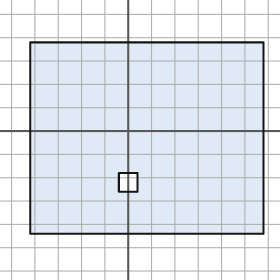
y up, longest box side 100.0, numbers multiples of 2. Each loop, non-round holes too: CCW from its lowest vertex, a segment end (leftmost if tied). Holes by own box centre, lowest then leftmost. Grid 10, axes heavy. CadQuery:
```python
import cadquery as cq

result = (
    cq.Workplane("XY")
    .moveTo(-42.0, -44.0)
    .lineTo(58.0, -44.0)
    .lineTo(58.0, 38.0)
    .lineTo(-42.0, 38.0)
    .close()
    .moveTo(-4.0, -26.0)
    .lineTo(4.0, -26.0)
    .lineTo(4.0, -18.0)
    .lineTo(-4.0, -18.0)
    .close()
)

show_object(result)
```